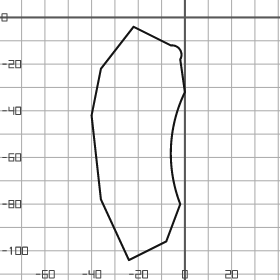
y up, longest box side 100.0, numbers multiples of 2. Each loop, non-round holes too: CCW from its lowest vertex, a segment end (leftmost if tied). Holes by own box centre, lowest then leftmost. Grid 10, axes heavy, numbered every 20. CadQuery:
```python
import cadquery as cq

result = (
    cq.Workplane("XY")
    .moveTo(-24.0, -104.0)
    .lineTo(-8.0, -96.0)
    .lineTo(-2.0, -80.0)
    .threePointArc((-6.0, -56.0), (0.0, -32.0))
    .lineTo(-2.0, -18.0)
    .threePointArc((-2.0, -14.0), (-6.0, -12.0))
    .lineTo(-22.0, -4.0)
    .lineTo(-36.0, -22.0)
    .lineTo(-40.0, -42.0)
    .lineTo(-36.0, -78.0)
    .close()
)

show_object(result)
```